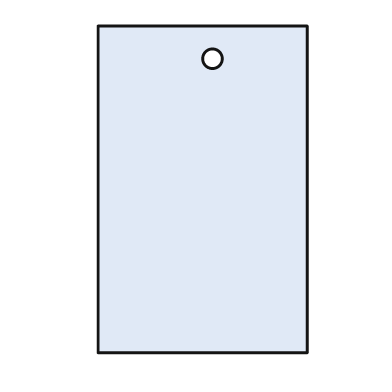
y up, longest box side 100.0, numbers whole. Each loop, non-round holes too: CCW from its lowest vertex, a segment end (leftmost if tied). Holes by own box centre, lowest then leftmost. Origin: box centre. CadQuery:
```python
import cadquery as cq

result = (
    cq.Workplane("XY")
    .moveTo(-32.0, -50.0)
    .lineTo(32.0, -50.0)
    .lineTo(32.0, 50.0)
    .lineTo(-32.0, 50.0)
    .close()
    .moveTo(3.0, 40.0)
    .circle(3.0)
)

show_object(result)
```